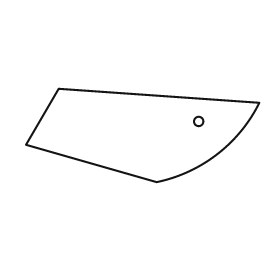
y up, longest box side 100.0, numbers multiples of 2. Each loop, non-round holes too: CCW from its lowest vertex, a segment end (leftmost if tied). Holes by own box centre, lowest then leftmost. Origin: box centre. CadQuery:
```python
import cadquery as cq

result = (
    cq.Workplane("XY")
    .moveTo(6.0, -20.0)
    .threePointArc((32.0, -8.0), (50.0, 14.0))
    .lineTo(-36.0, 20.0)
    .lineTo(-50.0, -4.0)
    .close()
    .moveTo(24.0, 6.0)
    .circle(2.0)
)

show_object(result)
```